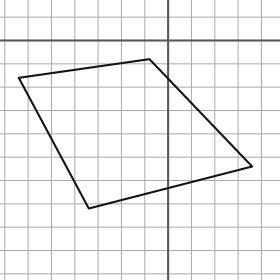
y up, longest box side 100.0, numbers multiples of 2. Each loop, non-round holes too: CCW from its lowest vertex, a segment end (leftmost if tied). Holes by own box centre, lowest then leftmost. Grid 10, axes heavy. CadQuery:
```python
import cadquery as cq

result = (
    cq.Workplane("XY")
    .moveTo(-34.0, -72.0)
    .lineTo(36.0, -54.0)
    .lineTo(-8.0, -8.0)
    .lineTo(-64.0, -16.0)
    .close()
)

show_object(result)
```